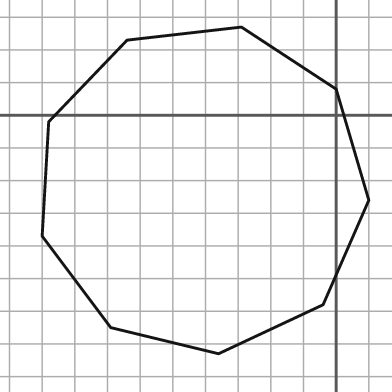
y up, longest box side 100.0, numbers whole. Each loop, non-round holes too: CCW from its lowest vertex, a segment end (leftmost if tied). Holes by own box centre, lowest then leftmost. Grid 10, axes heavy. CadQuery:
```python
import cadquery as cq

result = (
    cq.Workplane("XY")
    .moveTo(-36.0, -73.0)
    .lineTo(-4.0, -58.0)
    .lineTo(10.0, -26.0)
    .lineTo(0.0, 8.0)
    .lineTo(-29.0, 27.0)
    .lineTo(-64.0, 23.0)
    .lineTo(-88.0, -2.0)
    .lineTo(-90.0, -37.0)
    .lineTo(-69.0, -65.0)
    .close()
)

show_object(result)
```